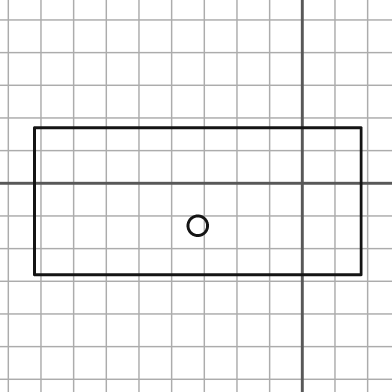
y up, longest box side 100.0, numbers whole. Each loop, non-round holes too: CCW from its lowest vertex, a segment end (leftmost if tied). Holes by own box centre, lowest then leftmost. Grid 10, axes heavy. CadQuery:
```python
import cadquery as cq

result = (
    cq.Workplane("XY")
    .moveTo(-82.0, -28.0)
    .lineTo(18.0, -28.0)
    .lineTo(18.0, 17.0)
    .lineTo(-82.0, 17.0)
    .close()
    .moveTo(-32.0, -13.0)
    .circle(3.0)
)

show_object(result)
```